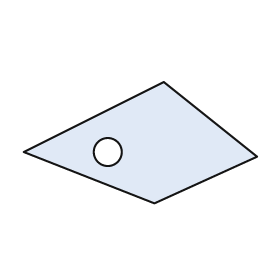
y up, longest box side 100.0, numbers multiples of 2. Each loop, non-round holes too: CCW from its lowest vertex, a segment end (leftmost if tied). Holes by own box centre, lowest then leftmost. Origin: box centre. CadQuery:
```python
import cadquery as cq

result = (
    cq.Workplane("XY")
    .moveTo(6.0, -26.0)
    .lineTo(50.0, -6.0)
    .lineTo(10.0, 26.0)
    .lineTo(-50.0, -4.0)
    .close()
    .moveTo(-14.0, -4.0)
    .circle(6.0)
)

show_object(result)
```